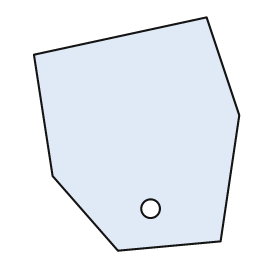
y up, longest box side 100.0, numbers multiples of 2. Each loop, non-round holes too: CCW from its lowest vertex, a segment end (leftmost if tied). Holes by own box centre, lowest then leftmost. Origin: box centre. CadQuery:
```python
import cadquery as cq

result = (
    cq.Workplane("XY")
    .moveTo(-8.0, -50.0)
    .lineTo(36.0, -46.0)
    .lineTo(44.0, 8.0)
    .lineTo(30.0, 50.0)
    .lineTo(-44.0, 34.0)
    .lineTo(-36.0, -18.0)
    .close()
    .moveTo(6.0, -32.0)
    .circle(4.0)
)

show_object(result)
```